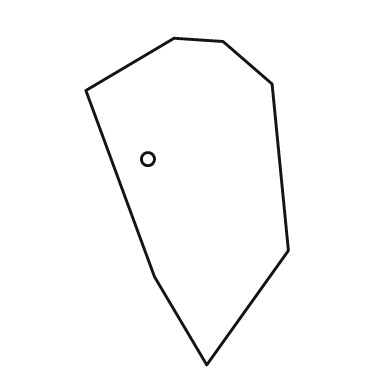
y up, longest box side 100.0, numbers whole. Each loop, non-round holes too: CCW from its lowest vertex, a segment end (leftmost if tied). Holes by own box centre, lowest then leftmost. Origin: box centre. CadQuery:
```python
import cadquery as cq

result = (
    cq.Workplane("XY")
    .moveTo(6.0, -50.0)
    .lineTo(31.0, -15.0)
    .lineTo(26.0, 36.0)
    .lineTo(11.0, 49.0)
    .lineTo(-4.0, 50.0)
    .lineTo(-31.0, 34.0)
    .lineTo(-10.0, -23.0)
    .close()
    .moveTo(-12.0, 13.0)
    .circle(2.0)
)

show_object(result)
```